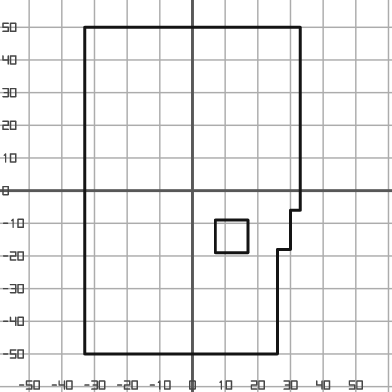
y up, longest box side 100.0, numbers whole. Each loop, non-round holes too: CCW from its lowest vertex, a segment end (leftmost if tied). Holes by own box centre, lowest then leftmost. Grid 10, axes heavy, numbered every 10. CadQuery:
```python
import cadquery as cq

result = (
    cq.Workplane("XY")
    .moveTo(-33.0, -50.0)
    .lineTo(26.0, -50.0)
    .lineTo(26.0, -18.0)
    .lineTo(30.0, -18.0)
    .lineTo(30.0, -6.0)
    .lineTo(33.0, -6.0)
    .lineTo(33.0, 50.0)
    .lineTo(-33.0, 50.0)
    .close()
    .moveTo(7.0, -19.0)
    .lineTo(17.0, -19.0)
    .lineTo(17.0, -9.0)
    .lineTo(7.0, -9.0)
    .close()
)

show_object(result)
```